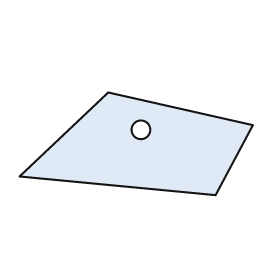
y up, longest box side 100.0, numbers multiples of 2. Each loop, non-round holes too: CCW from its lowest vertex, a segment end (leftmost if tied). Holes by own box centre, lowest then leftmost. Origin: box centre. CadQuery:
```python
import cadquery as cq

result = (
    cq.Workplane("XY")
    .moveTo(34.0, -22.0)
    .lineTo(50.0, 8.0)
    .lineTo(-12.0, 22.0)
    .lineTo(-50.0, -14.0)
    .close()
    .moveTo(2.0, 6.0)
    .circle(4.0)
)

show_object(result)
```